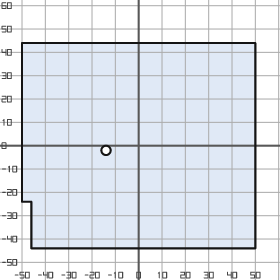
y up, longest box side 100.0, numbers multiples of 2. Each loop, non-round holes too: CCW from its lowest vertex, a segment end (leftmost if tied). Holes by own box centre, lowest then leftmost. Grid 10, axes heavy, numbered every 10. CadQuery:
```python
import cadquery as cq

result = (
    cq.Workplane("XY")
    .moveTo(-46.0, -44.0)
    .lineTo(50.0, -44.0)
    .lineTo(50.0, 44.0)
    .lineTo(-50.0, 44.0)
    .lineTo(-50.0, -24.0)
    .lineTo(-46.0, -24.0)
    .close()
    .moveTo(-14.0, -2.0)
    .circle(2.0)
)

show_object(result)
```